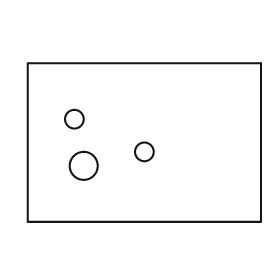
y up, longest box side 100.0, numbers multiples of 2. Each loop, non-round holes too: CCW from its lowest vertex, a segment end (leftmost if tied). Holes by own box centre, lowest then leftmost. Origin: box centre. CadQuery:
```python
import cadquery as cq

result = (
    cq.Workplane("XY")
    .moveTo(-50.0, -34.0)
    .lineTo(50.0, -34.0)
    .lineTo(50.0, 34.0)
    .lineTo(-50.0, 34.0)
    .close()
    .moveTo(-26.0, -10.0)
    .circle(6.0)
    .moveTo(0.0, -4.0)
    .circle(4.0)
    .moveTo(-30.0, 10.0)
    .circle(4.0)
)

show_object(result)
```